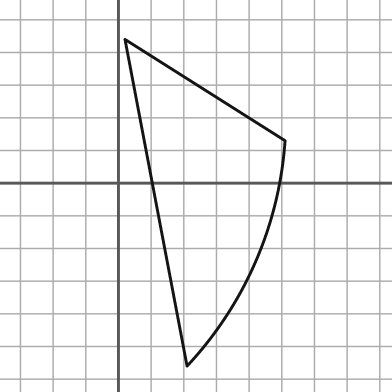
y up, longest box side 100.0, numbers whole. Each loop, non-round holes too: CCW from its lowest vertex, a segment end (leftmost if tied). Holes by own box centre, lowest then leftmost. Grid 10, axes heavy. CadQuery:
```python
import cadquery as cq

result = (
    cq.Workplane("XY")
    .moveTo(21.0, -56.0)
    .threePointArc((42.0, -24.0), (51.0, 13.0))
    .lineTo(2.0, 44.0)
    .close()
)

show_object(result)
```